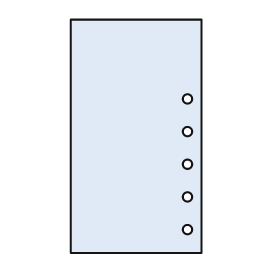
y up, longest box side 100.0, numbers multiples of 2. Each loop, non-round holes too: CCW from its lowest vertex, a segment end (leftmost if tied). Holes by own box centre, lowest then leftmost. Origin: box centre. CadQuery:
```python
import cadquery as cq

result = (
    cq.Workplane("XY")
    .moveTo(-28.0, -50.0)
    .lineTo(28.0, -50.0)
    .lineTo(28.0, 50.0)
    .lineTo(-28.0, 50.0)
    .close()
    .moveTo(22.0, -40.0)
    .circle(2.0)
    .moveTo(22.0, -26.0)
    .circle(2.0)
    .moveTo(22.0, -12.0)
    .circle(2.0)
    .moveTo(22.0, 2.0)
    .circle(2.0)
    .moveTo(22.0, 16.0)
    .circle(2.0)
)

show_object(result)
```